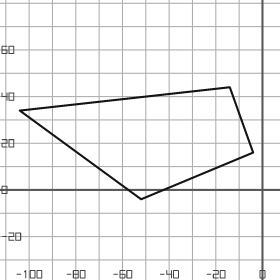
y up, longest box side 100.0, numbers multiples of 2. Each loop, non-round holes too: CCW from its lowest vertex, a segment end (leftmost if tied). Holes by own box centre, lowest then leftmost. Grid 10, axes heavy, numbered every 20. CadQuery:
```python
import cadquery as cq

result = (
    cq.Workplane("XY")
    .moveTo(-52.0, -4.0)
    .lineTo(-4.0, 16.0)
    .lineTo(-14.0, 44.0)
    .lineTo(-104.0, 34.0)
    .close()
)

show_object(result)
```